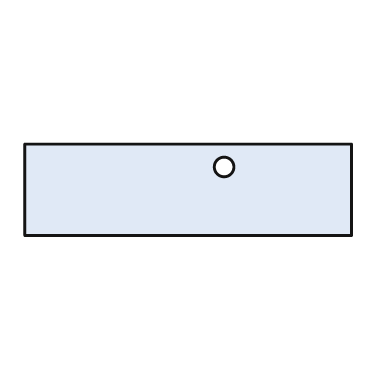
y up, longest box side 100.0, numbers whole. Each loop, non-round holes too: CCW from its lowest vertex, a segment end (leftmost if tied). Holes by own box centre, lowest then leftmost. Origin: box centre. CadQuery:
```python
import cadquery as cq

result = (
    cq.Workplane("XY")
    .moveTo(-50.0, -14.0)
    .lineTo(50.0, -14.0)
    .lineTo(50.0, 14.0)
    .lineTo(-50.0, 14.0)
    .close()
    .moveTo(11.0, 7.0)
    .circle(3.0)
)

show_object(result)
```